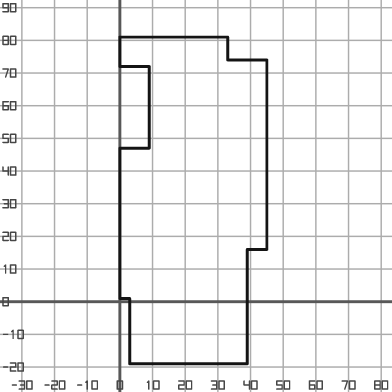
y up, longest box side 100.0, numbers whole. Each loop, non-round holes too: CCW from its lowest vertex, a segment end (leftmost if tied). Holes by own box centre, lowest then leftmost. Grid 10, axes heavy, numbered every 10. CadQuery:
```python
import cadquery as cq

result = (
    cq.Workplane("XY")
    .moveTo(3.0, -19.0)
    .lineTo(39.0, -19.0)
    .lineTo(39.0, 16.0)
    .lineTo(45.0, 16.0)
    .lineTo(45.0, 74.0)
    .lineTo(33.0, 74.0)
    .lineTo(33.0, 81.0)
    .lineTo(0.0, 81.0)
    .lineTo(0.0, 72.0)
    .lineTo(9.0, 72.0)
    .lineTo(9.0, 47.0)
    .lineTo(0.0, 47.0)
    .lineTo(0.0, 1.0)
    .lineTo(3.0, 1.0)
    .close()
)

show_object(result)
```